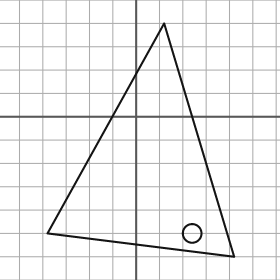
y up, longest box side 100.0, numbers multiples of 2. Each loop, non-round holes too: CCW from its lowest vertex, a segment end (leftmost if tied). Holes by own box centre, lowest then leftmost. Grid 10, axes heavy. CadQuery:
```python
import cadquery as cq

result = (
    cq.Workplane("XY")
    .moveTo(42.0, -60.0)
    .lineTo(12.0, 40.0)
    .lineTo(-38.0, -50.0)
    .close()
    .moveTo(24.0, -50.0)
    .circle(4.0)
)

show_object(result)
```